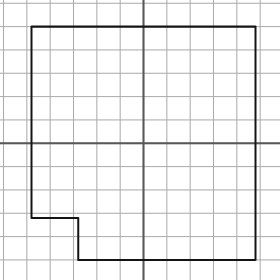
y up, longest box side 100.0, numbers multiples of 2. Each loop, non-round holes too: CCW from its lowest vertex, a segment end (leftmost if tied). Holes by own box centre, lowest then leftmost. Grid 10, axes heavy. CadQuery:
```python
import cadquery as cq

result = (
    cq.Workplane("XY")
    .moveTo(-28.0, -50.0)
    .lineTo(48.0, -50.0)
    .lineTo(48.0, 50.0)
    .lineTo(-48.0, 50.0)
    .lineTo(-48.0, -32.0)
    .lineTo(-28.0, -32.0)
    .close()
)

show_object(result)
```